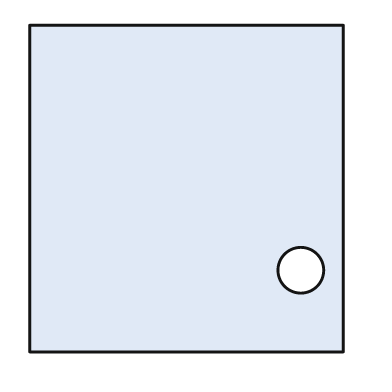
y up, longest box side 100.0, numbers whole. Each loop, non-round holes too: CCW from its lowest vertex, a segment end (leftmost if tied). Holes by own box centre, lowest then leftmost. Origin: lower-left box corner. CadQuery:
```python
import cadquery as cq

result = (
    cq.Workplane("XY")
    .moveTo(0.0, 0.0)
    .lineTo(96.0, 0.0)
    .lineTo(96.0, 100.0)
    .lineTo(0.0, 100.0)
    .close()
    .moveTo(83.0, 25.0)
    .circle(7.0)
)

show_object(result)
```